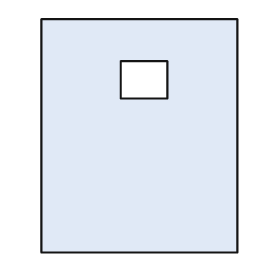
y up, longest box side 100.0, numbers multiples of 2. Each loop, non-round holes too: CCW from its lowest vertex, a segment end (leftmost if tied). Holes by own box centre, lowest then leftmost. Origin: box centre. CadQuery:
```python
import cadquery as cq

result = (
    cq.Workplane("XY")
    .moveTo(-42.0, -50.0)
    .lineTo(42.0, -50.0)
    .lineTo(42.0, 50.0)
    .lineTo(-42.0, 50.0)
    .close()
    .moveTo(-8.0, 16.0)
    .lineTo(12.0, 16.0)
    .lineTo(12.0, 32.0)
    .lineTo(-8.0, 32.0)
    .close()
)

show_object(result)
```